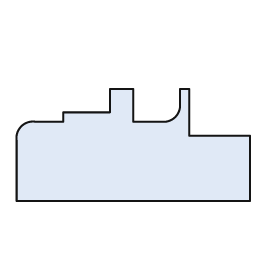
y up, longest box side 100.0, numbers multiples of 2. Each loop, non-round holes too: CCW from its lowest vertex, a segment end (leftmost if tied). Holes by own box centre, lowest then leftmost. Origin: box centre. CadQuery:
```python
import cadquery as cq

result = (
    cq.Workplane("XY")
    .moveTo(-50.0, -24.0)
    .lineTo(50.0, -24.0)
    .lineTo(50.0, 4.0)
    .lineTo(24.0, 4.0)
    .lineTo(24.0, 24.0)
    .lineTo(20.0, 24.0)
    .lineTo(20.0, 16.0)
    .threePointArc((18.0, 12.0), (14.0, 10.0))
    .lineTo(0.0, 10.0)
    .lineTo(0.0, 24.0)
    .lineTo(-10.0, 24.0)
    .lineTo(-10.0, 14.0)
    .lineTo(-30.0, 14.0)
    .lineTo(-30.0, 10.0)
    .lineTo(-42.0, 10.0)
    .threePointArc((-48.0, 8.0), (-50.0, 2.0))
    .close()
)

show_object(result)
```